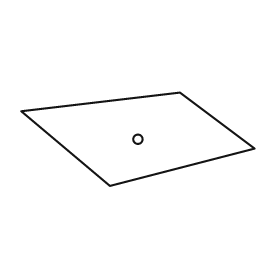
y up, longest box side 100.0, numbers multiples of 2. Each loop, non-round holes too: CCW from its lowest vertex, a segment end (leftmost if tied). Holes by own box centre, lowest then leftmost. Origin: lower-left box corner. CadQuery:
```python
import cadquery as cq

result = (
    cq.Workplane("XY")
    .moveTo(38.0, 0.0)
    .lineTo(100.0, 16.0)
    .lineTo(68.0, 40.0)
    .lineTo(0.0, 32.0)
    .close()
    .moveTo(50.0, 20.0)
    .circle(2.0)
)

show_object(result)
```